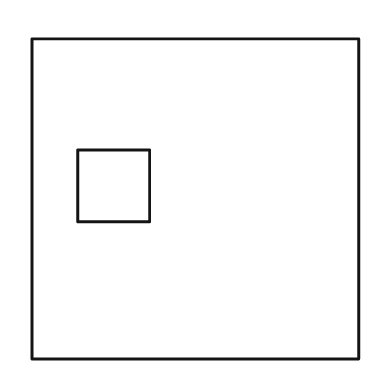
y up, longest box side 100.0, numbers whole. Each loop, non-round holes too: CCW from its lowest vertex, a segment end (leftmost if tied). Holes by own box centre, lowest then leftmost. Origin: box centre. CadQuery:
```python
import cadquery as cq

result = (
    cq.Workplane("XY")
    .moveTo(-50.0, -49.0)
    .lineTo(50.0, -49.0)
    .lineTo(50.0, 49.0)
    .lineTo(-50.0, 49.0)
    .close()
    .moveTo(-36.0, -7.0)
    .lineTo(-14.0, -7.0)
    .lineTo(-14.0, 15.0)
    .lineTo(-36.0, 15.0)
    .close()
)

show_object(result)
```